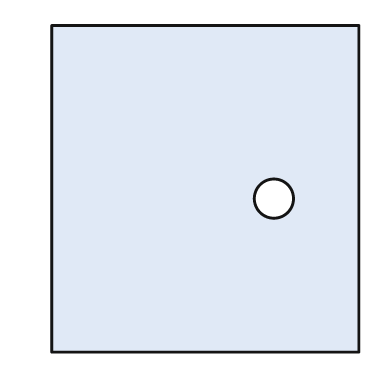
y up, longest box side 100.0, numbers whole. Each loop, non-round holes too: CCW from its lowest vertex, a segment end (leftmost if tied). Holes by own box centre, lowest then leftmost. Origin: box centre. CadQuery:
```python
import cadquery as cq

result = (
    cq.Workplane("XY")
    .moveTo(-47.0, -50.0)
    .lineTo(47.0, -50.0)
    .lineTo(47.0, 50.0)
    .lineTo(-47.0, 50.0)
    .close()
    .moveTo(21.0, -3.0)
    .circle(6.0)
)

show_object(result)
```